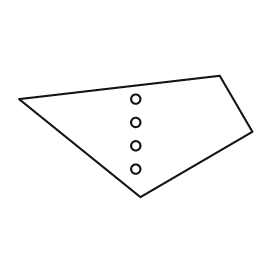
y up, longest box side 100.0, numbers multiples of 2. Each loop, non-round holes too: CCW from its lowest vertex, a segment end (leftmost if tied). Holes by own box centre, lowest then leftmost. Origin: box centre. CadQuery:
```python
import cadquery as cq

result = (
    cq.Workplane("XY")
    .moveTo(2.0, -26.0)
    .lineTo(50.0, 2.0)
    .lineTo(36.0, 26.0)
    .lineTo(-50.0, 16.0)
    .close()
    .moveTo(0.0, -14.0)
    .circle(2.0)
    .moveTo(0.0, -4.0)
    .circle(2.0)
    .moveTo(0.0, 6.0)
    .circle(2.0)
    .moveTo(0.0, 16.0)
    .circle(2.0)
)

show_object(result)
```